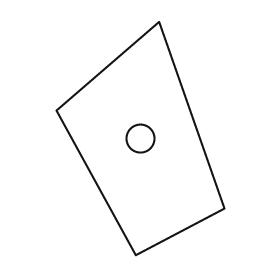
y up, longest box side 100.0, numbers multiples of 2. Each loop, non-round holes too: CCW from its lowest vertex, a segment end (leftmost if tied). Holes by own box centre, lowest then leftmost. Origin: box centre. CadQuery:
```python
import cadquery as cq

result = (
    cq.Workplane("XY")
    .moveTo(-2.0, -50.0)
    .lineTo(36.0, -30.0)
    .lineTo(8.0, 50.0)
    .lineTo(-36.0, 12.0)
    .close()
    .moveTo(0.0, 0.0)
    .circle(6.0)
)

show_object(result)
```